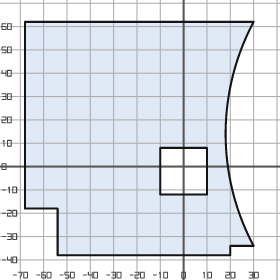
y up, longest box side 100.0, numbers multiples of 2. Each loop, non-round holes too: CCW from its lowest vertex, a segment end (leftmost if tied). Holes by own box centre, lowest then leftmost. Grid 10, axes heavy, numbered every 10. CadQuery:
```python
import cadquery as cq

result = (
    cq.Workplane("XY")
    .moveTo(-54.0, -38.0)
    .lineTo(20.0, -38.0)
    .lineTo(20.0, -34.0)
    .lineTo(30.0, -34.0)
    .threePointArc((18.0, 14.0), (30.0, 62.0))
    .lineTo(-68.0, 62.0)
    .lineTo(-68.0, -18.0)
    .lineTo(-54.0, -18.0)
    .close()
    .moveTo(-10.0, -12.0)
    .lineTo(10.0, -12.0)
    .lineTo(10.0, 8.0)
    .lineTo(-10.0, 8.0)
    .close()
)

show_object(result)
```